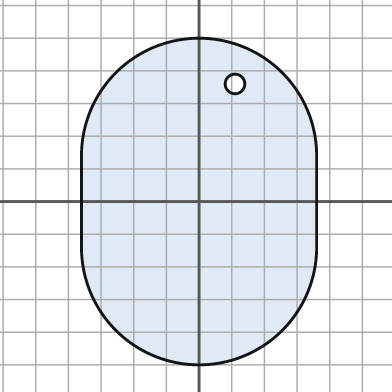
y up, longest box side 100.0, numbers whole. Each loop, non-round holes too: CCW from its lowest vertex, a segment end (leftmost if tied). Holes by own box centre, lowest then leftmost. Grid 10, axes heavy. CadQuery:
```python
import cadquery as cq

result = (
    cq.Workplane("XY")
    .moveTo(-36.0, -14.0)
    .threePointArc((0.0, -50.0), (36.0, -14.0))
    .lineTo(36.0, 14.0)
    .threePointArc((0.0, 50.0), (-36.0, 14.0))
    .close()
    .moveTo(11.0, 36.0)
    .circle(3.0)
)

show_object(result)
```